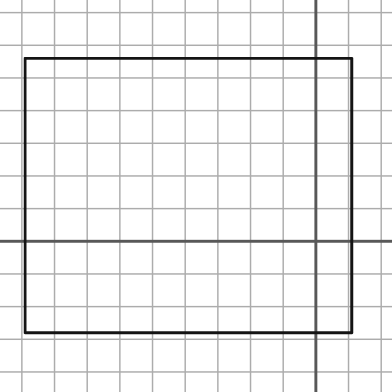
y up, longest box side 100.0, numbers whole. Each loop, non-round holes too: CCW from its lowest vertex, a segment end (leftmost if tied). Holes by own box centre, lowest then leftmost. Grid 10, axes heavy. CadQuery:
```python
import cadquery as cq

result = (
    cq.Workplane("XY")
    .moveTo(-89.0, -28.0)
    .lineTo(11.0, -28.0)
    .lineTo(11.0, 56.0)
    .lineTo(-89.0, 56.0)
    .close()
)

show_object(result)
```